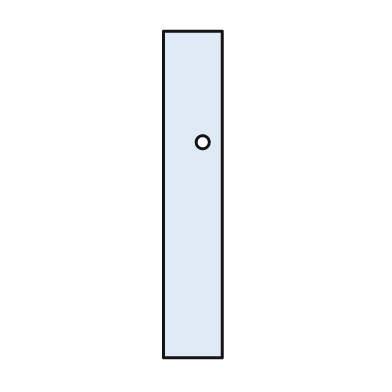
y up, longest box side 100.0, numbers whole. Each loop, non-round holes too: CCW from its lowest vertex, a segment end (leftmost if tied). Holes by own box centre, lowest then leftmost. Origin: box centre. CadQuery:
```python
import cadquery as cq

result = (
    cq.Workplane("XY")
    .moveTo(-9.0, -50.0)
    .lineTo(9.0, -50.0)
    .lineTo(9.0, 50.0)
    .lineTo(-9.0, 50.0)
    .close()
    .moveTo(3.0, 16.0)
    .circle(2.0)
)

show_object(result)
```